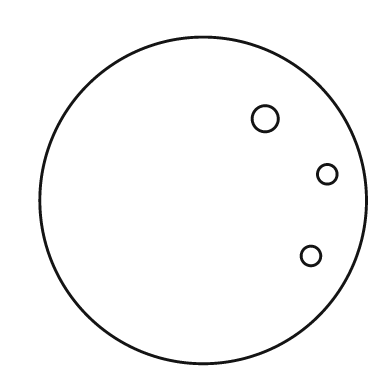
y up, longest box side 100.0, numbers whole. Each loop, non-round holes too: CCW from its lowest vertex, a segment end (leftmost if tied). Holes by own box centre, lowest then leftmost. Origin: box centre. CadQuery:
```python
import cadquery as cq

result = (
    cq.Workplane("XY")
    .moveTo(0.0, 0.0)
    .circle(50.0)
    .moveTo(33.0, -17.0)
    .circle(3.0)
    .moveTo(38.0, 8.0)
    .circle(3.0)
    .moveTo(19.0, 25.0)
    .circle(4.0)
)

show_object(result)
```